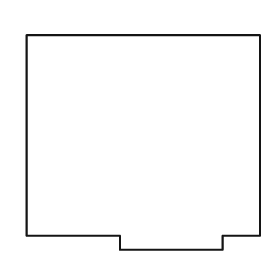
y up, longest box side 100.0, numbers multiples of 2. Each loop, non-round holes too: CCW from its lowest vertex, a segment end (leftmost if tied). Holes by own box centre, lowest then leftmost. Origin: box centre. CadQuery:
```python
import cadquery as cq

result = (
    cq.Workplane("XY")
    .moveTo(-10.0, -46.0)
    .lineTo(34.0, -46.0)
    .lineTo(34.0, -40.0)
    .lineTo(50.0, -40.0)
    .lineTo(50.0, 46.0)
    .lineTo(-50.0, 46.0)
    .lineTo(-50.0, -40.0)
    .lineTo(-10.0, -40.0)
    .close()
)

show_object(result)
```